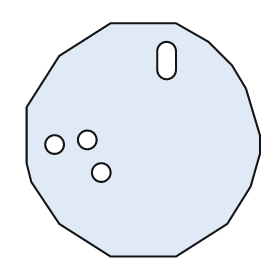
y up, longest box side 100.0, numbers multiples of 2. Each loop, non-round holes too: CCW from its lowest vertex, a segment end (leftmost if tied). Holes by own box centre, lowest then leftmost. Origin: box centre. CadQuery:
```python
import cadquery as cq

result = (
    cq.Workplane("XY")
    .moveTo(-14.0, -50.0)
    .lineTo(14.0, -50.0)
    .lineTo(36.0, -36.0)
    .lineTo(46.0, -20.0)
    .lineTo(50.0, -6.0)
    .lineTo(50.0, 2.0)
    .lineTo(44.0, 22.0)
    .lineTo(38.0, 32.0)
    .lineTo(28.0, 42.0)
    .lineTo(14.0, 50.0)
    .lineTo(-14.0, 50.0)
    .lineTo(-36.0, 36.0)
    .lineTo(-50.0, 14.0)
    .lineTo(-50.0, -10.0)
    .lineTo(-48.0, -18.0)
    .lineTo(-36.0, -36.0)
    .close()
    .moveTo(-18.0, -14.0)
    .circle(4.0)
    .moveTo(-38.0, -2.0)
    .circle(4.0)
    .moveTo(-24.0, 0.0)
    .circle(4.0)
    .moveTo(6.0, 30.0)
    .threePointArc((10.0, 26.0), (14.0, 30.0))
    .lineTo(14.0, 38.0)
    .threePointArc((10.0, 42.0), (6.0, 38.0))
    .close()
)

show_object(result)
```